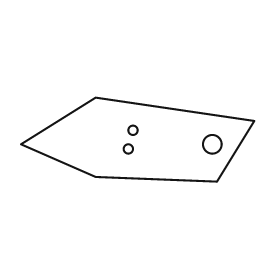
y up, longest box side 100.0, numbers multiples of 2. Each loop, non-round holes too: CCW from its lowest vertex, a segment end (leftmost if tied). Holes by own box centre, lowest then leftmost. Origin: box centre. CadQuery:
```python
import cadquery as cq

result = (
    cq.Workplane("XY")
    .moveTo(34.0, -18.0)
    .lineTo(50.0, 8.0)
    .lineTo(-18.0, 18.0)
    .lineTo(-50.0, -2.0)
    .lineTo(-18.0, -16.0)
    .close()
    .moveTo(-4.0, -4.0)
    .circle(2.0)
    .moveTo(32.0, -2.0)
    .circle(4.0)
    .moveTo(-2.0, 4.0)
    .circle(2.0)
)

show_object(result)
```